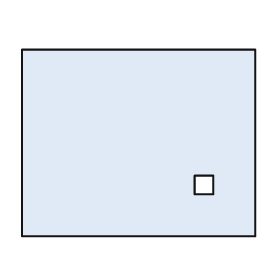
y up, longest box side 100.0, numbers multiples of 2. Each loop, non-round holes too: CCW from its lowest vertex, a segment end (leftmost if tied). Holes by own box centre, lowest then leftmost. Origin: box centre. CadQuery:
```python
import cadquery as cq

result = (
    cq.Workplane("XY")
    .moveTo(-50.0, -40.0)
    .lineTo(50.0, -40.0)
    .lineTo(50.0, 40.0)
    .lineTo(-50.0, 40.0)
    .close()
    .moveTo(24.0, -22.0)
    .lineTo(32.0, -22.0)
    .lineTo(32.0, -14.0)
    .lineTo(24.0, -14.0)
    .close()
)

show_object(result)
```